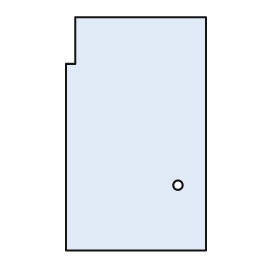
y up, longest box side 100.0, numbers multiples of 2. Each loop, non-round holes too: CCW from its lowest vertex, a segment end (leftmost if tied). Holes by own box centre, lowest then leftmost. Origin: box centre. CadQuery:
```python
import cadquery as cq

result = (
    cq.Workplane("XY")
    .moveTo(-30.0, -50.0)
    .lineTo(30.0, -50.0)
    .lineTo(30.0, 50.0)
    .lineTo(-26.0, 50.0)
    .lineTo(-26.0, 30.0)
    .lineTo(-30.0, 30.0)
    .close()
    .moveTo(18.0, -22.0)
    .circle(2.0)
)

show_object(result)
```